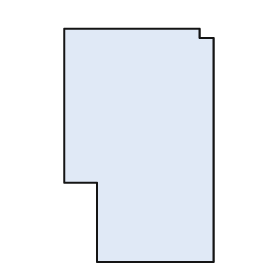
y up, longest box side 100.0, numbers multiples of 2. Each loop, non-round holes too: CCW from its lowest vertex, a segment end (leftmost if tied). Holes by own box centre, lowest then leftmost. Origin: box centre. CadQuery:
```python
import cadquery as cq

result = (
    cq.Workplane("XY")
    .moveTo(-18.0, -50.0)
    .lineTo(32.0, -50.0)
    .lineTo(32.0, 46.0)
    .lineTo(26.0, 46.0)
    .lineTo(26.0, 50.0)
    .lineTo(-32.0, 50.0)
    .lineTo(-32.0, -16.0)
    .lineTo(-18.0, -16.0)
    .close()
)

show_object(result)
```